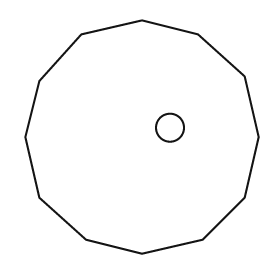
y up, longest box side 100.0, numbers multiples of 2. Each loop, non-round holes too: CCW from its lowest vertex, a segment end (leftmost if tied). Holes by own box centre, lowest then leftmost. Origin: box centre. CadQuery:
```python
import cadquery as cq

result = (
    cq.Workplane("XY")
    .moveTo(0.0, -50.0)
    .lineTo(26.0, -44.0)
    .lineTo(44.0, -26.0)
    .lineTo(50.0, 0.0)
    .lineTo(44.0, 26.0)
    .lineTo(24.0, 44.0)
    .lineTo(0.0, 50.0)
    .lineTo(-26.0, 44.0)
    .lineTo(-44.0, 24.0)
    .lineTo(-50.0, 0.0)
    .lineTo(-44.0, -26.0)
    .lineTo(-24.0, -44.0)
    .close()
    .moveTo(12.0, 4.0)
    .circle(6.0)
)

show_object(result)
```